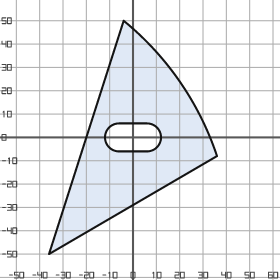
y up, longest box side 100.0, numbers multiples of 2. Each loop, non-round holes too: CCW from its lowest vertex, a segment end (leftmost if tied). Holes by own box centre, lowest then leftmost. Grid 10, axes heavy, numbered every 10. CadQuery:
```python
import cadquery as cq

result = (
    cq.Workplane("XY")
    .moveTo(-36.0, -50.0)
    .lineTo(36.0, -8.0)
    .threePointArc((20.0, 24.0), (-4.0, 50.0))
    .close()
    .moveTo(-6.0, -6.0)
    .lineTo(6.0, -6.0)
    .threePointArc((12.0, 0.0), (6.0, 6.0))
    .lineTo(-6.0, 6.0)
    .threePointArc((-12.0, 0.0), (-6.0, -6.0))
    .close()
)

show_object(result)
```